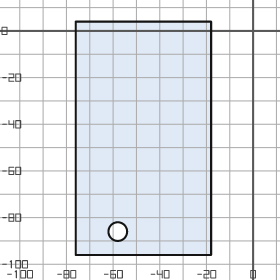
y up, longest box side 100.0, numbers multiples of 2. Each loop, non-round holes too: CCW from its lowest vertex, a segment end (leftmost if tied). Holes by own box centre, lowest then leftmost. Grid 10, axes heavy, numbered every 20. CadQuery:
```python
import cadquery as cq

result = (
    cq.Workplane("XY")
    .moveTo(-76.0, -96.0)
    .lineTo(-18.0, -96.0)
    .lineTo(-18.0, 4.0)
    .lineTo(-76.0, 4.0)
    .close()
    .moveTo(-58.0, -86.0)
    .circle(4.0)
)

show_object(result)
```